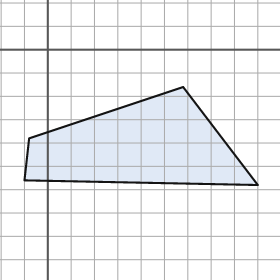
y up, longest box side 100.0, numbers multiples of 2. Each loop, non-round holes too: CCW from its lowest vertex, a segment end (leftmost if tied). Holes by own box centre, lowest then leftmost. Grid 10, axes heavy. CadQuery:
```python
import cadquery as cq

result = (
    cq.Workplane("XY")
    .moveTo(90.0, -58.0)
    .lineTo(58.0, -16.0)
    .lineTo(-8.0, -38.0)
    .lineTo(-10.0, -56.0)
    .close()
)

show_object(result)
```